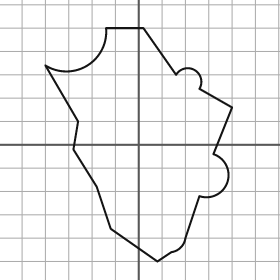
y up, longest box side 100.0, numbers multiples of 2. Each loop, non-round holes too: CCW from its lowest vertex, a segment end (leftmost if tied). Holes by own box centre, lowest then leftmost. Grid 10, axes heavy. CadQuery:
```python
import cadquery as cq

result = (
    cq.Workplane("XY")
    .moveTo(8.0, -50.0)
    .lineTo(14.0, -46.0)
    .threePointArc((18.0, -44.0), (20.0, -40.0))
    .lineTo(26.0, -22.0)
    .threePointArc((38.0, -16.0), (32.0, -4.0))
    .lineTo(40.0, 16.0)
    .lineTo(26.0, 24.0)
    .threePointArc((24.0, 32.0), (16.0, 30.0))
    .lineTo(2.0, 50.0)
    .lineTo(-14.0, 50.0)
    .threePointArc((-22.0, 34.0), (-40.0, 34.0))
    .lineTo(-26.0, 10.0)
    .lineTo(-28.0, -2.0)
    .lineTo(-18.0, -18.0)
    .lineTo(-12.0, -36.0)
    .close()
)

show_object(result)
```